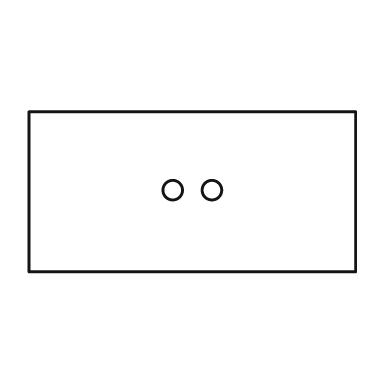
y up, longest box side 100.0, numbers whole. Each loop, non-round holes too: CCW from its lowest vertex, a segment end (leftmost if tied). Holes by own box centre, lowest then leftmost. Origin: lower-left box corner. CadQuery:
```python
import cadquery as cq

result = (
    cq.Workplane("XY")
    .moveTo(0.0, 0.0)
    .lineTo(100.0, 0.0)
    .lineTo(100.0, 49.0)
    .lineTo(0.0, 49.0)
    .close()
    .moveTo(44.0, 25.0)
    .circle(3.0)
    .moveTo(56.0, 25.0)
    .circle(3.0)
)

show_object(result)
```